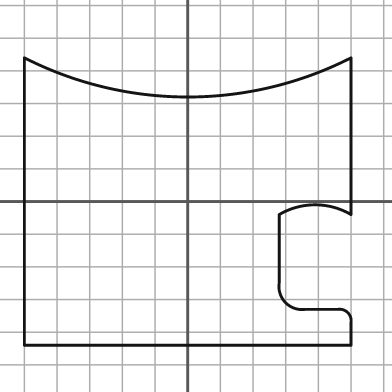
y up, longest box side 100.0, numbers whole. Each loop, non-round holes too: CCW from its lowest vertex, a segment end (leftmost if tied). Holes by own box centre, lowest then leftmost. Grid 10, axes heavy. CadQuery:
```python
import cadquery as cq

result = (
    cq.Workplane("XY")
    .moveTo(-50.0, -44.0)
    .lineTo(50.0, -44.0)
    .lineTo(50.0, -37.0)
    .threePointArc((49.0, -34.0), (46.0, -33.0))
    .lineTo(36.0, -33.0)
    .threePointArc((30.0, -31.0), (28.0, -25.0))
    .lineTo(28.0, -4.0)
    .threePointArc((39.0, -1.0), (50.0, -4.0))
    .lineTo(50.0, 44.0)
    .threePointArc((0.0, 32.0), (-50.0, 44.0))
    .close()
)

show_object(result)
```